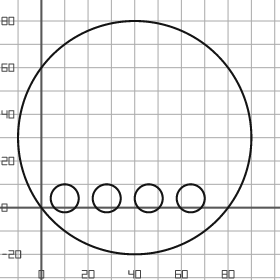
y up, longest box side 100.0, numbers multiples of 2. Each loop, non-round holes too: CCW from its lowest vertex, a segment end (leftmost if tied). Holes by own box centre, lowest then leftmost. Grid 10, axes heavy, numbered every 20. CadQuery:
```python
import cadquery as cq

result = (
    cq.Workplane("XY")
    .moveTo(40.0, 30.0)
    .circle(50.0)
    .moveTo(10.0, 4.0)
    .circle(6.0)
    .moveTo(28.0, 4.0)
    .circle(6.0)
    .moveTo(46.0, 4.0)
    .circle(6.0)
    .moveTo(64.0, 4.0)
    .circle(6.0)
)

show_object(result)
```